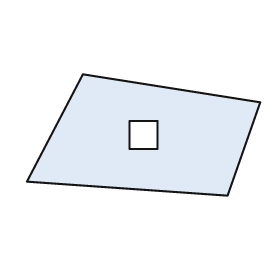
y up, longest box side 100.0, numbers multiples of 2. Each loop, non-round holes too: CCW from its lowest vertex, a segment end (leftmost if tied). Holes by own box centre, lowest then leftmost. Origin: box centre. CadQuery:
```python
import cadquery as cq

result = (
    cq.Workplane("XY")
    .moveTo(36.0, -26.0)
    .lineTo(50.0, 14.0)
    .lineTo(-26.0, 26.0)
    .lineTo(-50.0, -20.0)
    .close()
    .moveTo(-6.0, -6.0)
    .lineTo(6.0, -6.0)
    .lineTo(6.0, 6.0)
    .lineTo(-6.0, 6.0)
    .close()
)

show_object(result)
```